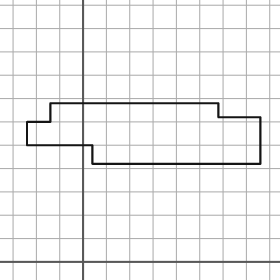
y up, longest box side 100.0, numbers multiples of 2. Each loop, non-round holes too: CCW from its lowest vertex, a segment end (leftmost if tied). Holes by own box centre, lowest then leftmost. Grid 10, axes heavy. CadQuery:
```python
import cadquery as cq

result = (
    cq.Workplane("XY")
    .moveTo(4.0, 42.0)
    .lineTo(76.0, 42.0)
    .lineTo(76.0, 62.0)
    .lineTo(58.0, 62.0)
    .lineTo(58.0, 68.0)
    .lineTo(-14.0, 68.0)
    .lineTo(-14.0, 60.0)
    .lineTo(-24.0, 60.0)
    .lineTo(-24.0, 50.0)
    .lineTo(4.0, 50.0)
    .close()
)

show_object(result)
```